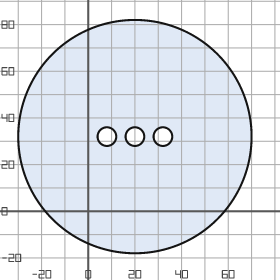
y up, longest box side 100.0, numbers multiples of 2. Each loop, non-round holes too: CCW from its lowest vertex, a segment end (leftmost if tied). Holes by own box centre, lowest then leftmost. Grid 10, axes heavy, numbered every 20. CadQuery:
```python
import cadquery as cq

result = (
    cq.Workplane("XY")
    .moveTo(20.0, 32.0)
    .circle(50.0)
    .moveTo(8.0, 32.0)
    .circle(4.0)
    .moveTo(20.0, 32.0)
    .circle(4.0)
    .moveTo(32.0, 32.0)
    .circle(4.0)
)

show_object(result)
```